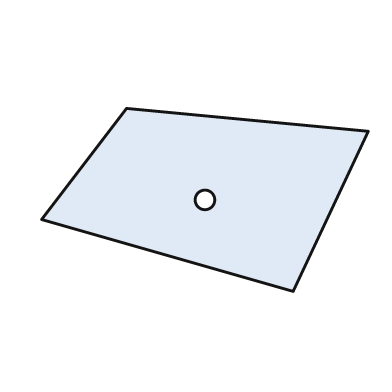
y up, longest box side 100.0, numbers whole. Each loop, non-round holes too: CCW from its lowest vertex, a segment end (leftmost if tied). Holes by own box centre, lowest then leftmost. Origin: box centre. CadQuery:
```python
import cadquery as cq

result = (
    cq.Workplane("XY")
    .moveTo(27.0, -28.0)
    .lineTo(50.0, 21.0)
    .lineTo(-24.0, 28.0)
    .lineTo(-50.0, -6.0)
    .close()
    .moveTo(0.0, 0.0)
    .circle(3.0)
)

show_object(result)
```